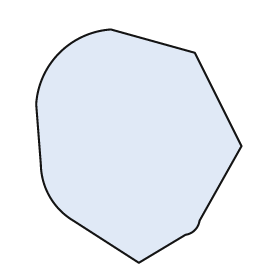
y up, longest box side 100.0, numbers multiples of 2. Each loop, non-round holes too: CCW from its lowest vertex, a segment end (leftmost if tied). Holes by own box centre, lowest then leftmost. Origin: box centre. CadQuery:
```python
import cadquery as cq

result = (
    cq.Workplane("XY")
    .moveTo(0.0, -50.0)
    .lineTo(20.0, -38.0)
    .threePointArc((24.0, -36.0), (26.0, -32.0))
    .lineTo(44.0, 0.0)
    .lineTo(24.0, 40.0)
    .lineTo(-12.0, 50.0)
    .threePointArc((-34.0, 40.0), (-44.0, 18.0))
    .lineTo(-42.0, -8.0)
    .threePointArc((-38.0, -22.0), (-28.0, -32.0))
    .close()
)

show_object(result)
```